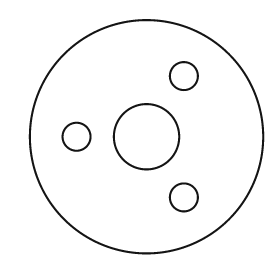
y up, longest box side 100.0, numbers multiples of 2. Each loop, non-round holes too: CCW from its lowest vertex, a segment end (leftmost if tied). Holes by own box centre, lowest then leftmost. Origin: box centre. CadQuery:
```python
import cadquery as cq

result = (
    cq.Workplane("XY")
    .moveTo(0.0, 0.0)
    .circle(50.0)
    .moveTo(16.0, -26.0)
    .circle(6.0)
    .moveTo(-30.0, 0.0)
    .circle(6.0)
    .moveTo(0.0, 0.0)
    .circle(14.0)
    .moveTo(16.0, 26.0)
    .circle(6.0)
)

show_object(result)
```